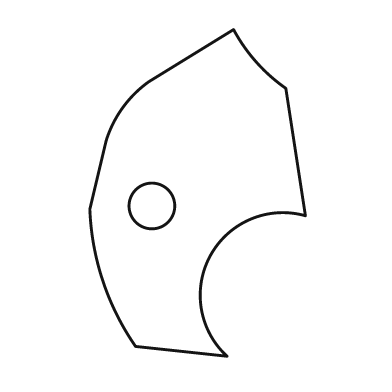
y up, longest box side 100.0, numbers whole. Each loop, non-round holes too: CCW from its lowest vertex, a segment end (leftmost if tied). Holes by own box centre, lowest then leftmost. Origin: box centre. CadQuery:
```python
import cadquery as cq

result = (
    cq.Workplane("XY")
    .moveTo(9.0, -50.0)
    .threePointArc((4.0, -19.0), (33.0, -7.0))
    .lineTo(27.0, 32.0)
    .threePointArc((18.0, 40.0), (11.0, 50.0))
    .lineTo(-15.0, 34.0)
    .threePointArc((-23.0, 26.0), (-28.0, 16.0))
    .lineTo(-33.0, -5.0)
    .threePointArc((-29.0, -27.0), (-19.0, -47.0))
    .close()
    .moveTo(-14.0, -4.0)
    .circle(7.0)
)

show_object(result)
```